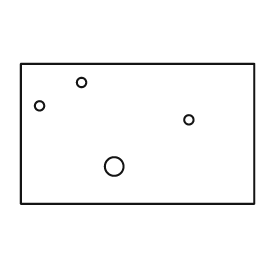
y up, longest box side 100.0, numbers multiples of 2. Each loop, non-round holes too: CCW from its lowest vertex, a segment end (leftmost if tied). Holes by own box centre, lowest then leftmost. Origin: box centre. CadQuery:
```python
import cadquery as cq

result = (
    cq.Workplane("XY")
    .moveTo(-50.0, -30.0)
    .lineTo(50.0, -30.0)
    .lineTo(50.0, 30.0)
    .lineTo(-50.0, 30.0)
    .close()
    .moveTo(-10.0, -14.0)
    .circle(4.0)
    .moveTo(22.0, 6.0)
    .circle(2.0)
    .moveTo(-42.0, 12.0)
    .circle(2.0)
    .moveTo(-24.0, 22.0)
    .circle(2.0)
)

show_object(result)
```